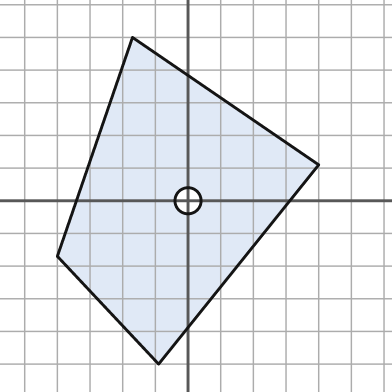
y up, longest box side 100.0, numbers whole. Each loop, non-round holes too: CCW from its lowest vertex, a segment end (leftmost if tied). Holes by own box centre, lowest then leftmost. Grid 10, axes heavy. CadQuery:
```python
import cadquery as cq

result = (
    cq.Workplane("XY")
    .moveTo(-9.0, -50.0)
    .lineTo(40.0, 11.0)
    .lineTo(-17.0, 50.0)
    .lineTo(-40.0, -17.0)
    .close()
    .moveTo(0.0, 0.0)
    .circle(4.0)
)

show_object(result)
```